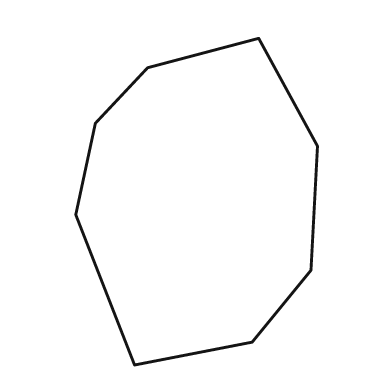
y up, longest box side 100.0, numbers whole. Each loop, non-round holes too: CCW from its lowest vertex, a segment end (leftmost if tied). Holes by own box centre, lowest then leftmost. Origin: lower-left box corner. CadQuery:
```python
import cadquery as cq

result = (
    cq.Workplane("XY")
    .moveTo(18.0, 0.0)
    .lineTo(54.0, 7.0)
    .lineTo(72.0, 29.0)
    .lineTo(74.0, 67.0)
    .lineTo(56.0, 100.0)
    .lineTo(22.0, 91.0)
    .lineTo(6.0, 74.0)
    .lineTo(0.0, 46.0)
    .close()
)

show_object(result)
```